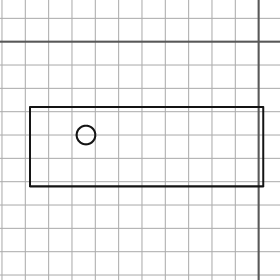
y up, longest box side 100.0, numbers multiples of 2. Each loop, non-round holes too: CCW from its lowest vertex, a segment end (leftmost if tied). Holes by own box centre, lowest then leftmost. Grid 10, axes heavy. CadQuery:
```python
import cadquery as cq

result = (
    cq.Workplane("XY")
    .moveTo(-98.0, -62.0)
    .lineTo(2.0, -62.0)
    .lineTo(2.0, -28.0)
    .lineTo(-98.0, -28.0)
    .close()
    .moveTo(-74.0, -40.0)
    .circle(4.0)
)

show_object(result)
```